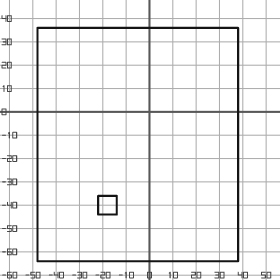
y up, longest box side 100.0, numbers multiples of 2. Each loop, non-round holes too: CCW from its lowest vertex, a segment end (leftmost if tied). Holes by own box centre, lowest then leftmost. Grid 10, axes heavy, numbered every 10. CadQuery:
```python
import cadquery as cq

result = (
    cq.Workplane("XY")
    .moveTo(-48.0, -64.0)
    .lineTo(38.0, -64.0)
    .lineTo(38.0, 36.0)
    .lineTo(-48.0, 36.0)
    .close()
    .moveTo(-22.0, -44.0)
    .lineTo(-14.0, -44.0)
    .lineTo(-14.0, -36.0)
    .lineTo(-22.0, -36.0)
    .close()
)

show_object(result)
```